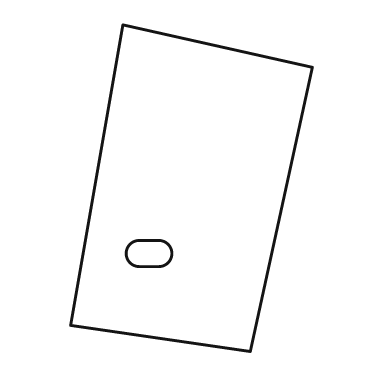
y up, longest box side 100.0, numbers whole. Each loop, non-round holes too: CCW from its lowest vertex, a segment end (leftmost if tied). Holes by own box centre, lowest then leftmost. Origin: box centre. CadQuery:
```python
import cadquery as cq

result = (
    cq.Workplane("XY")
    .moveTo(18.0, -50.0)
    .lineTo(37.0, 37.0)
    .lineTo(-21.0, 50.0)
    .lineTo(-37.0, -42.0)
    .close()
    .moveTo(-16.0, -24.0)
    .lineTo(-10.0, -24.0)
    .threePointArc((-6.0, -20.0), (-10.0, -16.0))
    .lineTo(-16.0, -16.0)
    .threePointArc((-20.0, -20.0), (-16.0, -24.0))
    .close()
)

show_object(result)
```